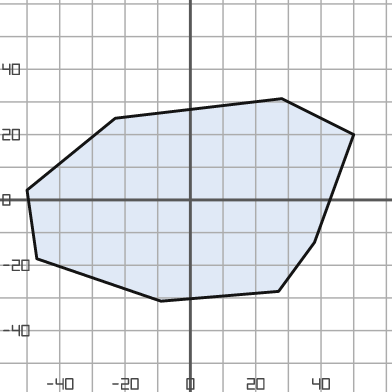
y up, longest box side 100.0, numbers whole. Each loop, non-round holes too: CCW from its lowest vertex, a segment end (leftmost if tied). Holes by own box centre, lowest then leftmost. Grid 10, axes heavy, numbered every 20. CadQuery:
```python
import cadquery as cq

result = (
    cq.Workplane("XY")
    .moveTo(-9.0, -31.0)
    .lineTo(27.0, -28.0)
    .lineTo(38.0, -13.0)
    .lineTo(50.0, 20.0)
    .lineTo(28.0, 31.0)
    .lineTo(-23.0, 25.0)
    .lineTo(-50.0, 3.0)
    .lineTo(-47.0, -18.0)
    .close()
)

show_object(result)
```